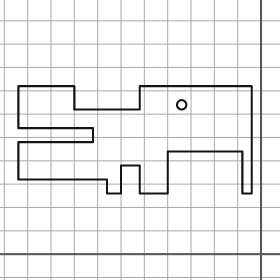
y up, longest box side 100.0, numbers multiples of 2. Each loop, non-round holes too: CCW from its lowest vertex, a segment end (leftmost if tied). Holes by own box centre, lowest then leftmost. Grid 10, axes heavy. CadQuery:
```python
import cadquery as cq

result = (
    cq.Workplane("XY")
    .moveTo(-66.0, 26.0)
    .lineTo(-60.0, 26.0)
    .lineTo(-60.0, 38.0)
    .lineTo(-52.0, 38.0)
    .lineTo(-52.0, 26.0)
    .lineTo(-40.0, 26.0)
    .lineTo(-40.0, 44.0)
    .lineTo(-8.0, 44.0)
    .lineTo(-8.0, 26.0)
    .lineTo(-4.0, 26.0)
    .lineTo(-4.0, 72.0)
    .lineTo(-52.0, 72.0)
    .lineTo(-52.0, 62.0)
    .lineTo(-80.0, 62.0)
    .lineTo(-80.0, 72.0)
    .lineTo(-104.0, 72.0)
    .lineTo(-104.0, 54.0)
    .lineTo(-72.0, 54.0)
    .lineTo(-72.0, 48.0)
    .lineTo(-104.0, 48.0)
    .lineTo(-104.0, 32.0)
    .lineTo(-66.0, 32.0)
    .close()
    .moveTo(-34.0, 64.0)
    .circle(2.0)
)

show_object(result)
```